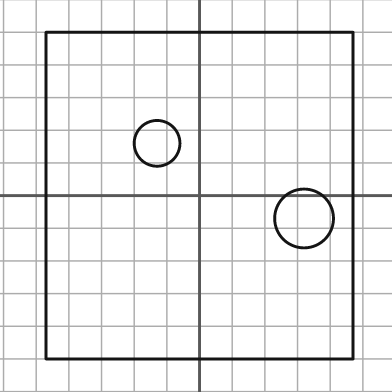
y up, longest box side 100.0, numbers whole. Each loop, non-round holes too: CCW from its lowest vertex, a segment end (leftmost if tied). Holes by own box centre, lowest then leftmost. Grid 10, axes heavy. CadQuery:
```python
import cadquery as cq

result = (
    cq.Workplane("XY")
    .moveTo(-47.0, -50.0)
    .lineTo(47.0, -50.0)
    .lineTo(47.0, 50.0)
    .lineTo(-47.0, 50.0)
    .close()
    .moveTo(32.0, -7.0)
    .circle(9.0)
    .moveTo(-13.0, 16.0)
    .circle(7.0)
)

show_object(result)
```